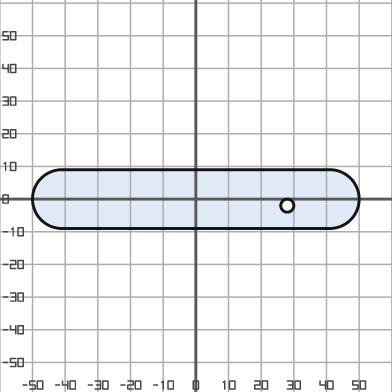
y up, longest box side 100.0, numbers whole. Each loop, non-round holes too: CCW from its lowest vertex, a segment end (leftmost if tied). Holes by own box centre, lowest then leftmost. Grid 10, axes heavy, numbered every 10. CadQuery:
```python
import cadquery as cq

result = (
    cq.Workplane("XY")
    .moveTo(-41.0, -9.0)
    .lineTo(41.0, -9.0)
    .threePointArc((50.0, 0.0), (41.0, 9.0))
    .lineTo(-41.0, 9.0)
    .threePointArc((-50.0, 0.0), (-41.0, -9.0))
    .close()
    .moveTo(28.0, -2.0)
    .circle(2.0)
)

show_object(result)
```